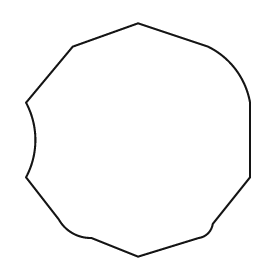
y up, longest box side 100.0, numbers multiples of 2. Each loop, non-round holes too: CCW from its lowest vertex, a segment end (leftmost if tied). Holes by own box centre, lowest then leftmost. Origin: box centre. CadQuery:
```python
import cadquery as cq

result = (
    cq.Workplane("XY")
    .moveTo(0.0, -50.0)
    .lineTo(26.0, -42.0)
    .threePointArc((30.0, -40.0), (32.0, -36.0))
    .lineTo(48.0, -16.0)
    .lineTo(48.0, 16.0)
    .threePointArc((42.0, 30.0), (30.0, 40.0))
    .lineTo(0.0, 50.0)
    .lineTo(-28.0, 40.0)
    .lineTo(-48.0, 16.0)
    .threePointArc((-44.0, 0.0), (-48.0, -16.0))
    .lineTo(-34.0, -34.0)
    .threePointArc((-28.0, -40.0), (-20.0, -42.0))
    .close()
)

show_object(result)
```